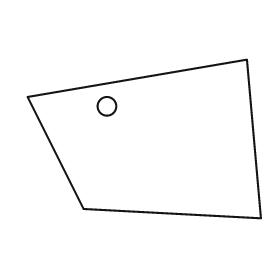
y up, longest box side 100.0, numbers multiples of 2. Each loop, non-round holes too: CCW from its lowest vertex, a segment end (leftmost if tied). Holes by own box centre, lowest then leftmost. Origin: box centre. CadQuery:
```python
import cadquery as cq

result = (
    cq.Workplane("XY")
    .moveTo(50.0, -34.0)
    .lineTo(44.0, 34.0)
    .lineTo(-50.0, 18.0)
    .lineTo(-26.0, -30.0)
    .close()
    .moveTo(-16.0, 14.0)
    .circle(4.0)
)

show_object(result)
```